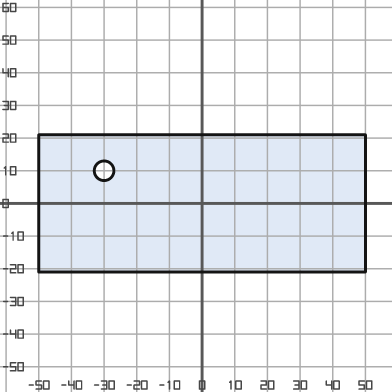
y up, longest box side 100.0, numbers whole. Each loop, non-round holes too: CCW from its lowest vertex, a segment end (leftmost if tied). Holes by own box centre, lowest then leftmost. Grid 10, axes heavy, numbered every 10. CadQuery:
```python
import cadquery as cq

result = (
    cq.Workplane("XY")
    .moveTo(-50.0, -21.0)
    .lineTo(50.0, -21.0)
    .lineTo(50.0, 21.0)
    .lineTo(-50.0, 21.0)
    .close()
    .moveTo(-30.0, 10.0)
    .circle(3.0)
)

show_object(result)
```